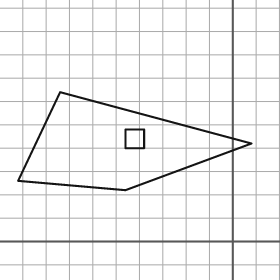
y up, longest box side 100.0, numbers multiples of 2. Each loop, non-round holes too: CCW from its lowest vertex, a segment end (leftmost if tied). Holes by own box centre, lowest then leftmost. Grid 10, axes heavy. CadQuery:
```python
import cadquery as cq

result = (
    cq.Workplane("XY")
    .moveTo(-46.0, 22.0)
    .lineTo(8.0, 42.0)
    .lineTo(-74.0, 64.0)
    .lineTo(-92.0, 26.0)
    .close()
    .moveTo(-46.0, 40.0)
    .lineTo(-38.0, 40.0)
    .lineTo(-38.0, 48.0)
    .lineTo(-46.0, 48.0)
    .close()
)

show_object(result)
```